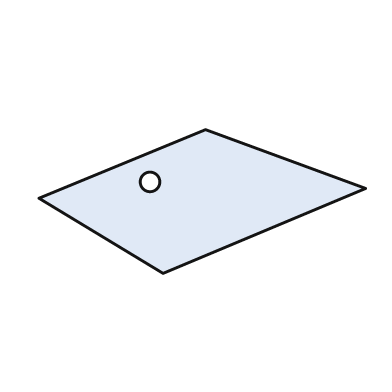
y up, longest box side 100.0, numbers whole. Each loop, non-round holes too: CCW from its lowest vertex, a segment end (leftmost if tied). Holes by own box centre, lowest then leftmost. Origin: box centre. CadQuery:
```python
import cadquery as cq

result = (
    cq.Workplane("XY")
    .moveTo(-12.0, -22.0)
    .lineTo(50.0, 4.0)
    .lineTo(1.0, 22.0)
    .lineTo(-50.0, 1.0)
    .close()
    .moveTo(-16.0, 6.0)
    .circle(3.0)
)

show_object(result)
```